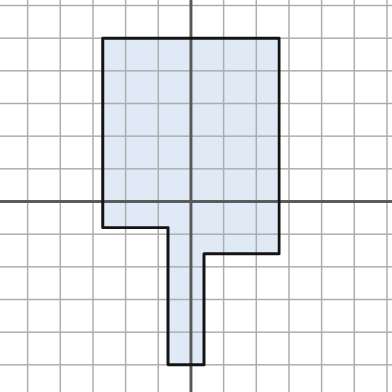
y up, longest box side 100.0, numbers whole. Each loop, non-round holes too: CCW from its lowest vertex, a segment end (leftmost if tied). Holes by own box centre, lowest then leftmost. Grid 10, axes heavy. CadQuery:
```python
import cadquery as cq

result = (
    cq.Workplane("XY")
    .moveTo(-7.0, -50.0)
    .lineTo(4.0, -50.0)
    .lineTo(4.0, -16.0)
    .lineTo(27.0, -16.0)
    .lineTo(27.0, 50.0)
    .lineTo(-27.0, 50.0)
    .lineTo(-27.0, -8.0)
    .lineTo(-7.0, -8.0)
    .close()
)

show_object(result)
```